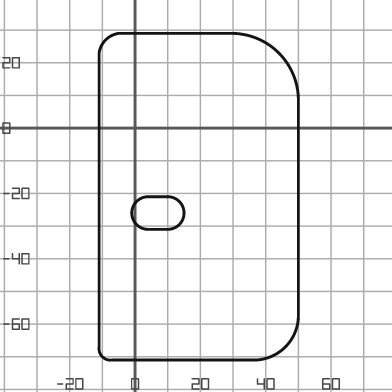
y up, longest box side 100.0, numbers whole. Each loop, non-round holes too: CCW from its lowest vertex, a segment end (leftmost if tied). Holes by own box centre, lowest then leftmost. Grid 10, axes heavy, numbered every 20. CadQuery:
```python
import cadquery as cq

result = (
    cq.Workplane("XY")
    .moveTo(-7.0, -71.0)
    .lineTo(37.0, -71.0)
    .threePointArc((46.0, -67.0), (50.0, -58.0))
    .lineTo(50.0, 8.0)
    .threePointArc((44.0, 23.0), (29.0, 29.0))
    .lineTo(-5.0, 29.0)
    .threePointArc((-9.0, 27.0), (-11.0, 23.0))
    .lineTo(-11.0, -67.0)
    .threePointArc((-10.0, -70.0), (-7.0, -71.0))
    .close()
    .moveTo(4.0, -31.0)
    .lineTo(10.0, -31.0)
    .threePointArc((15.0, -26.0), (10.0, -21.0))
    .lineTo(4.0, -21.0)
    .threePointArc((-1.0, -26.0), (4.0, -31.0))
    .close()
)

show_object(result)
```